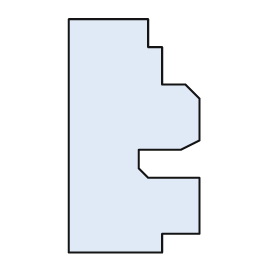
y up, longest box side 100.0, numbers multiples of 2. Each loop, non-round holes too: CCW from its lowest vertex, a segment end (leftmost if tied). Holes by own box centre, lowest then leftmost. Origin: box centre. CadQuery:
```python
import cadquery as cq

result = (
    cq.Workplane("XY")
    .moveTo(-28.0, -50.0)
    .lineTo(12.0, -50.0)
    .lineTo(12.0, -42.0)
    .lineTo(28.0, -42.0)
    .lineTo(28.0, -18.0)
    .lineTo(6.0, -18.0)
    .lineTo(2.0, -14.0)
    .lineTo(2.0, -6.0)
    .lineTo(20.0, -6.0)
    .lineTo(28.0, -2.0)
    .lineTo(28.0, 16.0)
    .lineTo(22.0, 22.0)
    .lineTo(12.0, 22.0)
    .lineTo(12.0, 38.0)
    .lineTo(6.0, 38.0)
    .lineTo(6.0, 50.0)
    .lineTo(-28.0, 50.0)
    .close()
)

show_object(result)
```